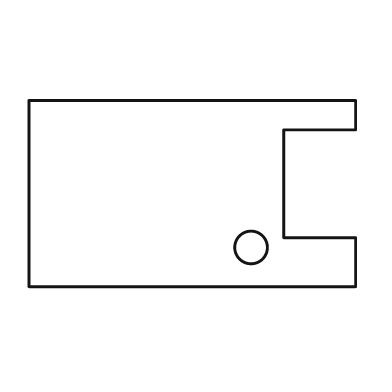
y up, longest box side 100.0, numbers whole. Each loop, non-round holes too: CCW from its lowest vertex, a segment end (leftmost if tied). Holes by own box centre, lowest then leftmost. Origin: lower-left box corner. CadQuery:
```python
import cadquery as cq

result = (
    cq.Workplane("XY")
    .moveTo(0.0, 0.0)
    .lineTo(100.0, 0.0)
    .lineTo(100.0, 15.0)
    .lineTo(78.0, 15.0)
    .lineTo(78.0, 48.0)
    .lineTo(100.0, 48.0)
    .lineTo(100.0, 57.0)
    .lineTo(0.0, 57.0)
    .close()
    .moveTo(68.0, 12.0)
    .circle(5.0)
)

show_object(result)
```